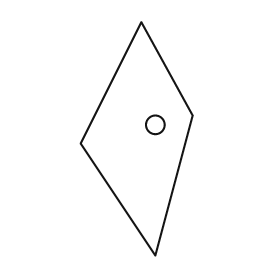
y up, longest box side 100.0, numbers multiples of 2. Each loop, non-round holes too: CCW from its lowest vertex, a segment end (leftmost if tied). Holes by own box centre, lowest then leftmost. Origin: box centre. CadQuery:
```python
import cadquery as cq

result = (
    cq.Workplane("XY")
    .moveTo(8.0, -50.0)
    .lineTo(24.0, 10.0)
    .lineTo(2.0, 50.0)
    .lineTo(-24.0, -2.0)
    .close()
    .moveTo(8.0, 6.0)
    .circle(4.0)
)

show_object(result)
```